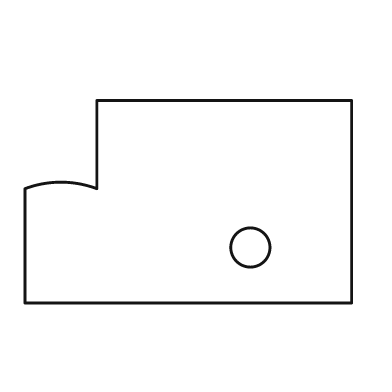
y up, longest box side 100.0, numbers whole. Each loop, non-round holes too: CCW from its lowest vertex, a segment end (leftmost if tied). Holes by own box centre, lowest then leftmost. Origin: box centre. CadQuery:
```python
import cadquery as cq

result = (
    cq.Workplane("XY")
    .moveTo(-50.0, -31.0)
    .lineTo(50.0, -31.0)
    .lineTo(50.0, 31.0)
    .lineTo(-28.0, 31.0)
    .lineTo(-28.0, 4.0)
    .threePointArc((-39.0, 6.0), (-50.0, 4.0))
    .close()
    .moveTo(19.0, -14.0)
    .circle(6.0)
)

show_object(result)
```